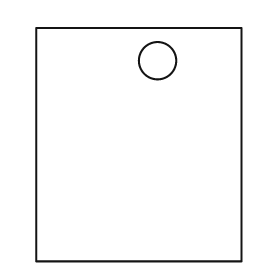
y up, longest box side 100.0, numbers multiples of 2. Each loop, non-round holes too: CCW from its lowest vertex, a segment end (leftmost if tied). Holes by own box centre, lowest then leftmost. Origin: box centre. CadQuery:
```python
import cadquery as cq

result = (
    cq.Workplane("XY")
    .moveTo(-44.0, -50.0)
    .lineTo(44.0, -50.0)
    .lineTo(44.0, 50.0)
    .lineTo(-44.0, 50.0)
    .close()
    .moveTo(8.0, 36.0)
    .circle(8.0)
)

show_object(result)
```